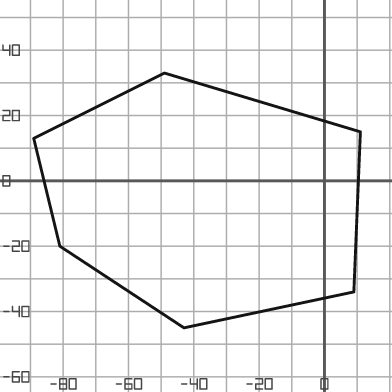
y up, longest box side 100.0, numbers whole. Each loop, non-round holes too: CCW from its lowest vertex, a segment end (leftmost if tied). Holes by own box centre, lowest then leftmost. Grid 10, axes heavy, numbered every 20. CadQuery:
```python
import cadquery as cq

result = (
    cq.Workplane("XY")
    .moveTo(-43.0, -45.0)
    .lineTo(9.0, -34.0)
    .lineTo(11.0, 15.0)
    .lineTo(-49.0, 33.0)
    .lineTo(-89.0, 13.0)
    .lineTo(-81.0, -20.0)
    .close()
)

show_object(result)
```